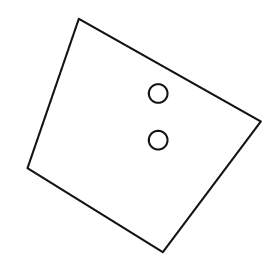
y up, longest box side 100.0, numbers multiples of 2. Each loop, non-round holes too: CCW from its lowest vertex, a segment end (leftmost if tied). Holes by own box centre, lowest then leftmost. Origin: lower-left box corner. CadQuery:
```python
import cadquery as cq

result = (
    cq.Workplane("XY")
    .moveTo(58.0, 0.0)
    .lineTo(100.0, 56.0)
    .lineTo(22.0, 100.0)
    .lineTo(0.0, 36.0)
    .close()
    .moveTo(56.0, 48.0)
    .circle(4.0)
    .moveTo(56.0, 68.0)
    .circle(4.0)
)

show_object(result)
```